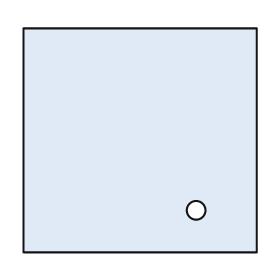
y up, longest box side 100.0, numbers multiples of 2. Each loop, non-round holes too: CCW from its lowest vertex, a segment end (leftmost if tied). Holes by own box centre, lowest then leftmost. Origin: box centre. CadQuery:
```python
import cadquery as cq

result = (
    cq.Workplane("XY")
    .moveTo(-50.0, -48.0)
    .lineTo(50.0, -48.0)
    .lineTo(50.0, 48.0)
    .lineTo(-50.0, 48.0)
    .close()
    .moveTo(24.0, -30.0)
    .circle(4.0)
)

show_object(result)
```